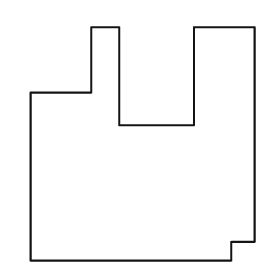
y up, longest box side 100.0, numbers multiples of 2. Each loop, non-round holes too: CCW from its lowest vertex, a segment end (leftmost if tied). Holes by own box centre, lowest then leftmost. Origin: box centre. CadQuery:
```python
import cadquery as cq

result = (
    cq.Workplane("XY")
    .moveTo(-48.0, -50.0)
    .lineTo(38.0, -50.0)
    .lineTo(38.0, -42.0)
    .lineTo(48.0, -42.0)
    .lineTo(48.0, 50.0)
    .lineTo(22.0, 50.0)
    .lineTo(22.0, 8.0)
    .lineTo(-10.0, 8.0)
    .lineTo(-10.0, 50.0)
    .lineTo(-22.0, 50.0)
    .lineTo(-22.0, 22.0)
    .lineTo(-48.0, 22.0)
    .close()
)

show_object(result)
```